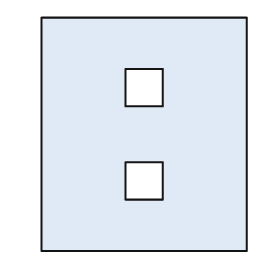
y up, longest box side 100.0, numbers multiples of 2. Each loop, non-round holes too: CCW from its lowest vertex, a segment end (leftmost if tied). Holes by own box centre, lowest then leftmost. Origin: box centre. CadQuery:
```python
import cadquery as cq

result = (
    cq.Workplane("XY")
    .moveTo(-44.0, -50.0)
    .lineTo(44.0, -50.0)
    .lineTo(44.0, 50.0)
    .lineTo(-44.0, 50.0)
    .close()
    .moveTo(-8.0, -28.0)
    .lineTo(8.0, -28.0)
    .lineTo(8.0, -12.0)
    .lineTo(-8.0, -12.0)
    .close()
    .moveTo(-8.0, 12.0)
    .lineTo(8.0, 12.0)
    .lineTo(8.0, 28.0)
    .lineTo(-8.0, 28.0)
    .close()
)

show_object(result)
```